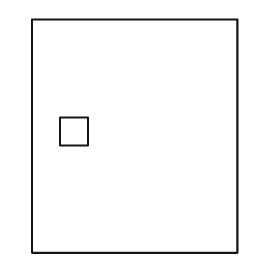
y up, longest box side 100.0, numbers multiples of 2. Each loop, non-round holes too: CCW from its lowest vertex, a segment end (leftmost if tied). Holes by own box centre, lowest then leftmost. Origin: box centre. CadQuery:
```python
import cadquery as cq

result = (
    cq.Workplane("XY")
    .moveTo(-44.0, -50.0)
    .lineTo(44.0, -50.0)
    .lineTo(44.0, 50.0)
    .lineTo(-44.0, 50.0)
    .close()
    .moveTo(-32.0, -4.0)
    .lineTo(-20.0, -4.0)
    .lineTo(-20.0, 8.0)
    .lineTo(-32.0, 8.0)
    .close()
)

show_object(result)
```